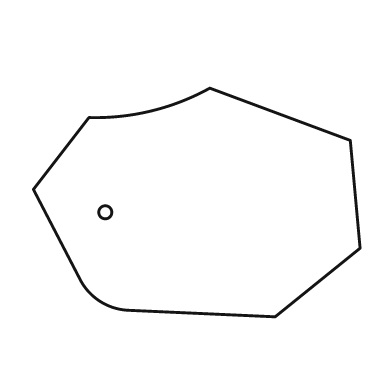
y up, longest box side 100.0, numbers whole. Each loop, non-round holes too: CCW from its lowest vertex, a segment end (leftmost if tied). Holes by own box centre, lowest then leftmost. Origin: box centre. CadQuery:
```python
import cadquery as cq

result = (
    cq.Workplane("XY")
    .moveTo(24.0, -35.0)
    .lineTo(50.0, -14.0)
    .lineTo(47.0, 19.0)
    .lineTo(4.0, 35.0)
    .threePointArc((-14.0, 28.0), (-33.0, 26.0))
    .lineTo(-50.0, 4.0)
    .lineTo(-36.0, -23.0)
    .threePointArc((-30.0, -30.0), (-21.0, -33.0))
    .close()
    .moveTo(-28.0, -3.0)
    .circle(2.0)
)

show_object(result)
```